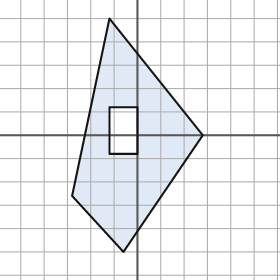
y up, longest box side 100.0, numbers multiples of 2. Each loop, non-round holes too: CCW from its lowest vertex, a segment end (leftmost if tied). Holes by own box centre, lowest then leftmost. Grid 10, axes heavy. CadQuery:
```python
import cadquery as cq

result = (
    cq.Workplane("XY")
    .moveTo(-6.0, -50.0)
    .lineTo(28.0, 0.0)
    .lineTo(-12.0, 50.0)
    .lineTo(-28.0, -26.0)
    .close()
    .moveTo(-12.0, -8.0)
    .lineTo(0.0, -8.0)
    .lineTo(0.0, 12.0)
    .lineTo(-12.0, 12.0)
    .close()
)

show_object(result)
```